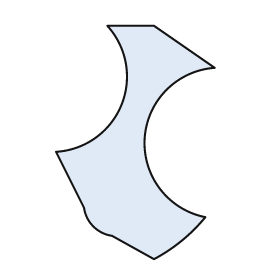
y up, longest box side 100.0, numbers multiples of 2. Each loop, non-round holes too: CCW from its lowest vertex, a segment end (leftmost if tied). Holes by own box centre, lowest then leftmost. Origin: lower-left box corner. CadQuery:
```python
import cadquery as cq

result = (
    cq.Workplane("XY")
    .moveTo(42.0, 0.0)
    .threePointArc((54.0, 8.0), (64.0, 18.0))
    .threePointArc((38.0, 52.0), (68.0, 82.0))
    .lineTo(42.0, 100.0)
    .lineTo(22.0, 100.0)
    .threePointArc((28.0, 66.0), (0.0, 46.0))
    .lineTo(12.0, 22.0)
    .threePointArc((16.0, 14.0), (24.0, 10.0))
    .close()
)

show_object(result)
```